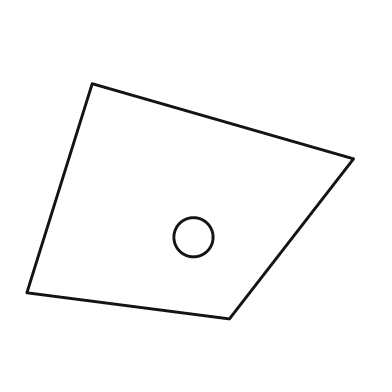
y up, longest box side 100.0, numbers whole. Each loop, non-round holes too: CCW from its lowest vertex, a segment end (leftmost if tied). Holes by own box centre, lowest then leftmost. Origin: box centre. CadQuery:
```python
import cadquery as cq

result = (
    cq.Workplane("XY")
    .moveTo(12.0, -36.0)
    .lineTo(50.0, 13.0)
    .lineTo(-30.0, 36.0)
    .lineTo(-50.0, -28.0)
    .close()
    .moveTo(1.0, -11.0)
    .circle(6.0)
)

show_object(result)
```